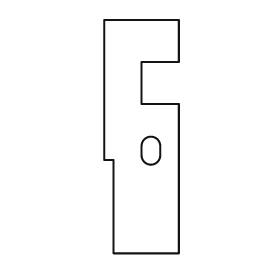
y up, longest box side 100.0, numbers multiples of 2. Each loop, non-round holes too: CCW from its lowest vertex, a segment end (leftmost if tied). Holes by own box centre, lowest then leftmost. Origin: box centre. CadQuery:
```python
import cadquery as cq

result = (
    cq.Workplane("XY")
    .moveTo(-12.0, -50.0)
    .lineTo(16.0, -50.0)
    .lineTo(16.0, 14.0)
    .lineTo(0.0, 14.0)
    .lineTo(0.0, 32.0)
    .lineTo(16.0, 32.0)
    .lineTo(16.0, 50.0)
    .lineTo(-16.0, 50.0)
    .lineTo(-16.0, -10.0)
    .lineTo(-12.0, -10.0)
    .close()
    .moveTo(0.0, -8.0)
    .threePointArc((4.0, -12.0), (8.0, -8.0))
    .lineTo(8.0, -4.0)
    .threePointArc((4.0, 0.0), (0.0, -4.0))
    .close()
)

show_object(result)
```